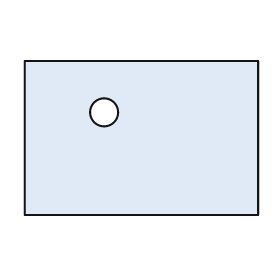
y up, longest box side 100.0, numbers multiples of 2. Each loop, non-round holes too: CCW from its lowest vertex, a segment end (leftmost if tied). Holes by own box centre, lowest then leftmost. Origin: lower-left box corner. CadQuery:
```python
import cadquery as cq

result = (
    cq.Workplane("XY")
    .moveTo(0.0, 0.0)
    .lineTo(100.0, 0.0)
    .lineTo(100.0, 66.0)
    .lineTo(0.0, 66.0)
    .close()
    .moveTo(34.0, 44.0)
    .circle(6.0)
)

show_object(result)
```